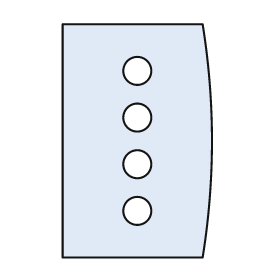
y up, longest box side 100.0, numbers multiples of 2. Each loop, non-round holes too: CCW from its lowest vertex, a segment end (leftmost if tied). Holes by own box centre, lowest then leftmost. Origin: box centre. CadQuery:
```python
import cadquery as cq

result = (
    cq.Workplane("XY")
    .moveTo(-32.0, -50.0)
    .lineTo(28.0, -50.0)
    .threePointArc((32.0, 0.0), (28.0, 50.0))
    .lineTo(-32.0, 50.0)
    .close()
    .moveTo(0.0, -30.0)
    .circle(6.0)
    .moveTo(0.0, -10.0)
    .circle(6.0)
    .moveTo(0.0, 10.0)
    .circle(6.0)
    .moveTo(0.0, 30.0)
    .circle(6.0)
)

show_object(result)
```